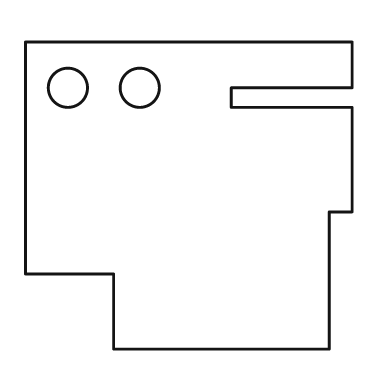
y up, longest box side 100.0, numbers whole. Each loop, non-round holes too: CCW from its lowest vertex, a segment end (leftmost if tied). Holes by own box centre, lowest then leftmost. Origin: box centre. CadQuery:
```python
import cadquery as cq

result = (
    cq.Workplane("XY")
    .moveTo(-23.0, -47.0)
    .lineTo(43.0, -47.0)
    .lineTo(43.0, -5.0)
    .lineTo(50.0, -5.0)
    .lineTo(50.0, 27.0)
    .lineTo(13.0, 27.0)
    .lineTo(13.0, 33.0)
    .lineTo(50.0, 33.0)
    .lineTo(50.0, 47.0)
    .lineTo(-50.0, 47.0)
    .lineTo(-50.0, -24.0)
    .lineTo(-23.0, -24.0)
    .close()
    .moveTo(-37.0, 33.0)
    .circle(6.0)
    .moveTo(-15.0, 33.0)
    .circle(6.0)
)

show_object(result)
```